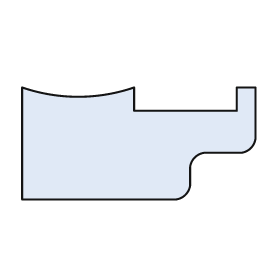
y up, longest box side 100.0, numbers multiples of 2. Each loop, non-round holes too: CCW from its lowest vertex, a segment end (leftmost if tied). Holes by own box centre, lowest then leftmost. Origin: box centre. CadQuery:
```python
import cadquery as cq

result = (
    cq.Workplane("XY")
    .moveTo(-50.0, -24.0)
    .lineTo(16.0, -24.0)
    .threePointArc((20.0, -22.0), (22.0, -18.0))
    .lineTo(22.0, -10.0)
    .threePointArc((24.0, -6.0), (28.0, -4.0))
    .lineTo(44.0, -4.0)
    .threePointArc((48.0, -2.0), (50.0, 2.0))
    .lineTo(50.0, 24.0)
    .lineTo(42.0, 24.0)
    .lineTo(42.0, 14.0)
    .lineTo(-2.0, 14.0)
    .lineTo(-2.0, 24.0)
    .threePointArc((-26.0, 20.0), (-50.0, 24.0))
    .close()
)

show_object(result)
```